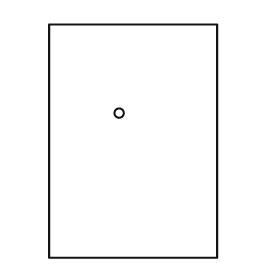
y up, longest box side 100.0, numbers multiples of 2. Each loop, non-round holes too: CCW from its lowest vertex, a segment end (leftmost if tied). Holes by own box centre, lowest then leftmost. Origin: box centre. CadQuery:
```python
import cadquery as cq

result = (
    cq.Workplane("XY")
    .moveTo(-36.0, -50.0)
    .lineTo(36.0, -50.0)
    .lineTo(36.0, 50.0)
    .lineTo(-36.0, 50.0)
    .close()
    .moveTo(-6.0, 12.0)
    .circle(2.0)
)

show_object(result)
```